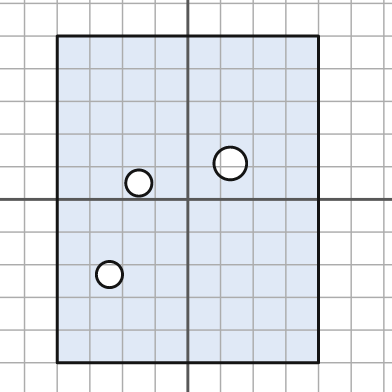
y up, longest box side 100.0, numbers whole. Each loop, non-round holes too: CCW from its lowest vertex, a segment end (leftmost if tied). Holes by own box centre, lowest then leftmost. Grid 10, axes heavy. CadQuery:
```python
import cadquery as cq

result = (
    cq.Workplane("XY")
    .moveTo(-40.0, -50.0)
    .lineTo(40.0, -50.0)
    .lineTo(40.0, 50.0)
    .lineTo(-40.0, 50.0)
    .close()
    .moveTo(-24.0, -23.0)
    .circle(4.0)
    .moveTo(-15.0, 5.0)
    .circle(4.0)
    .moveTo(13.0, 11.0)
    .circle(5.0)
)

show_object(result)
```